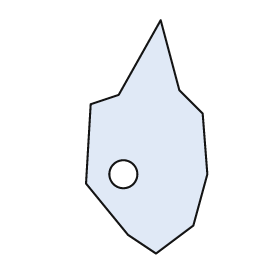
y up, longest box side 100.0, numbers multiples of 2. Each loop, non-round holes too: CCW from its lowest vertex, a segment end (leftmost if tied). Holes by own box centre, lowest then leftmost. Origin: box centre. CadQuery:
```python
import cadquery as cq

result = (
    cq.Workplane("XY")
    .moveTo(4.0, -50.0)
    .lineTo(20.0, -38.0)
    .lineTo(26.0, -16.0)
    .lineTo(24.0, 10.0)
    .lineTo(14.0, 20.0)
    .lineTo(6.0, 50.0)
    .lineTo(-12.0, 18.0)
    .lineTo(-24.0, 14.0)
    .lineTo(-26.0, -20.0)
    .lineTo(-8.0, -42.0)
    .close()
    .moveTo(-10.0, -16.0)
    .circle(6.0)
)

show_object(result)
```